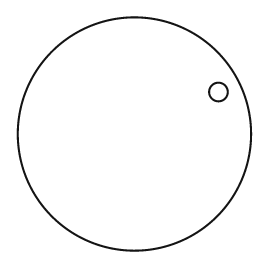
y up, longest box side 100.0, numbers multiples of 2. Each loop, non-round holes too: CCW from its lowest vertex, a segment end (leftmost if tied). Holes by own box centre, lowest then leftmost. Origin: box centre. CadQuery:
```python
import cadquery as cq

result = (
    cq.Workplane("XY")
    .moveTo(0.0, 0.0)
    .circle(50.0)
    .moveTo(36.0, 18.0)
    .circle(4.0)
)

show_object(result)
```